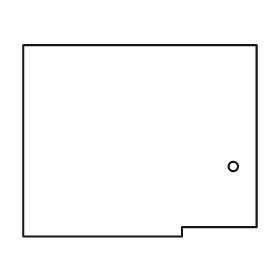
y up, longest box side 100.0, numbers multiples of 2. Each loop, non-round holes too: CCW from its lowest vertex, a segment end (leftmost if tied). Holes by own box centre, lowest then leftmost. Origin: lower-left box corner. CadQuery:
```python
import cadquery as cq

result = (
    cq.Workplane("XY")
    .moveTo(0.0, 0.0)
    .lineTo(68.0, 0.0)
    .lineTo(68.0, 4.0)
    .lineTo(100.0, 4.0)
    .lineTo(100.0, 82.0)
    .lineTo(0.0, 82.0)
    .close()
    .moveTo(90.0, 30.0)
    .circle(2.0)
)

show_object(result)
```